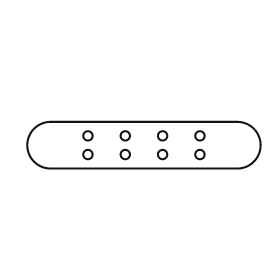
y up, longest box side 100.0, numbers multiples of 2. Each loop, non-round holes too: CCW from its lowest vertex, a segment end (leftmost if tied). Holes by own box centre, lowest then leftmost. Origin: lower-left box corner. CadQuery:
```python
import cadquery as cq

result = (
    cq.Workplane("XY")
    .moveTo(10.0, 0.0)
    .lineTo(90.0, 0.0)
    .threePointArc((100.0, 10.0), (90.0, 20.0))
    .lineTo(10.0, 20.0)
    .threePointArc((0.0, 10.0), (10.0, 0.0))
    .close()
    .moveTo(26.0, 6.0)
    .circle(2.0)
    .moveTo(42.0, 6.0)
    .circle(2.0)
    .moveTo(58.0, 6.0)
    .circle(2.0)
    .moveTo(74.0, 6.0)
    .circle(2.0)
    .moveTo(26.0, 14.0)
    .circle(2.0)
    .moveTo(42.0, 14.0)
    .circle(2.0)
    .moveTo(58.0, 14.0)
    .circle(2.0)
    .moveTo(74.0, 14.0)
    .circle(2.0)
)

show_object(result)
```